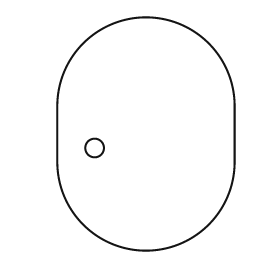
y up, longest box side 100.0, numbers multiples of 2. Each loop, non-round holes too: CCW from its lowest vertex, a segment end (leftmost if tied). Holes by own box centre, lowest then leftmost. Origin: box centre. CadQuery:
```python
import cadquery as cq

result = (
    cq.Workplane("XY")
    .moveTo(-38.0, -12.0)
    .threePointArc((0.0, -50.0), (38.0, -12.0))
    .lineTo(38.0, 12.0)
    .threePointArc((0.0, 50.0), (-38.0, 12.0))
    .close()
    .moveTo(-22.0, -6.0)
    .circle(4.0)
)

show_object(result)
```